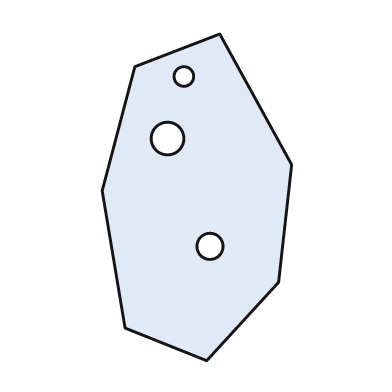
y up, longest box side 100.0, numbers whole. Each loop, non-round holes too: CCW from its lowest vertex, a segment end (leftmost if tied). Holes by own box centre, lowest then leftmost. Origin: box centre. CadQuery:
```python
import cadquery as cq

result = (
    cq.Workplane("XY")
    .moveTo(3.0, -50.0)
    .lineTo(25.0, -26.0)
    .lineTo(29.0, 10.0)
    .lineTo(7.0, 50.0)
    .lineTo(-19.0, 40.0)
    .lineTo(-29.0, 2.0)
    .lineTo(-22.0, -40.0)
    .close()
    .moveTo(4.0, -15.0)
    .circle(4.0)
    .moveTo(-9.0, 18.0)
    .circle(5.0)
    .moveTo(-4.0, 37.0)
    .circle(3.0)
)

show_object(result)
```